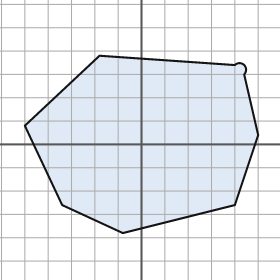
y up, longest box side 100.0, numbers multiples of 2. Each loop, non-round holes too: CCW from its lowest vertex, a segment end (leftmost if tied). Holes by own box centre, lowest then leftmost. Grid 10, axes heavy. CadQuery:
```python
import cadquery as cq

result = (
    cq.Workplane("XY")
    .moveTo(-8.0, -38.0)
    .lineTo(40.0, -26.0)
    .lineTo(50.0, 4.0)
    .lineTo(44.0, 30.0)
    .threePointArc((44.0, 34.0), (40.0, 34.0))
    .lineTo(-18.0, 38.0)
    .lineTo(-50.0, 8.0)
    .lineTo(-34.0, -26.0)
    .close()
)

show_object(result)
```